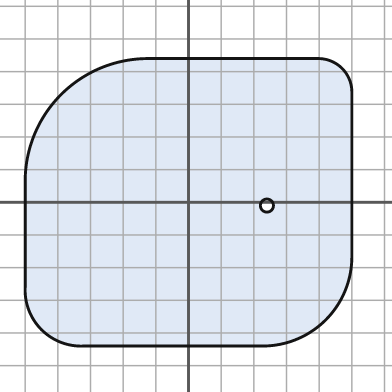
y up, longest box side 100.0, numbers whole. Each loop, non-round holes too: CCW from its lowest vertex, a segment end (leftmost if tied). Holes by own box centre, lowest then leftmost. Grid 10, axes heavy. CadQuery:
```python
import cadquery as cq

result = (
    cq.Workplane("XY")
    .moveTo(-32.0, -44.0)
    .lineTo(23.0, -44.0)
    .threePointArc((42.0, -36.0), (50.0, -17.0))
    .lineTo(50.0, 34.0)
    .threePointArc((47.0, 41.0), (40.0, 44.0))
    .lineTo(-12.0, 44.0)
    .threePointArc((-39.0, 33.0), (-50.0, 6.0))
    .lineTo(-50.0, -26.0)
    .threePointArc((-45.0, -39.0), (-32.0, -44.0))
    .close()
    .moveTo(24.0, -1.0)
    .circle(2.0)
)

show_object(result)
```